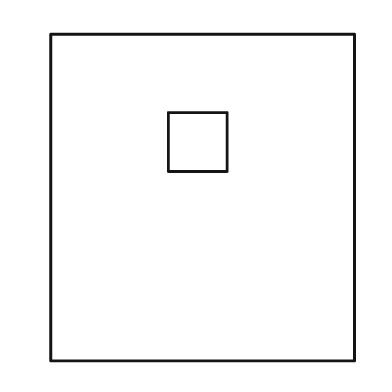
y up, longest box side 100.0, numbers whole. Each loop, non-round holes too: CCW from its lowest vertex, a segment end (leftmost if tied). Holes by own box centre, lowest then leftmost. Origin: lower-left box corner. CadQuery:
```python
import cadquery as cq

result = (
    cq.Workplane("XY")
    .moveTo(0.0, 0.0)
    .lineTo(93.0, 0.0)
    .lineTo(93.0, 100.0)
    .lineTo(0.0, 100.0)
    .close()
    .moveTo(36.0, 58.0)
    .lineTo(54.0, 58.0)
    .lineTo(54.0, 76.0)
    .lineTo(36.0, 76.0)
    .close()
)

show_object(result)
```